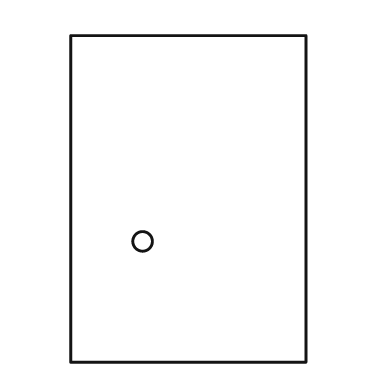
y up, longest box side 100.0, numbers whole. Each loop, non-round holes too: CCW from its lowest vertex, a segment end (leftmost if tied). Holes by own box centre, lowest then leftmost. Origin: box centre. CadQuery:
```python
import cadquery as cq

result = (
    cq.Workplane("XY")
    .moveTo(-36.0, -50.0)
    .lineTo(36.0, -50.0)
    .lineTo(36.0, 50.0)
    .lineTo(-36.0, 50.0)
    .close()
    .moveTo(-14.0, -13.0)
    .circle(3.0)
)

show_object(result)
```